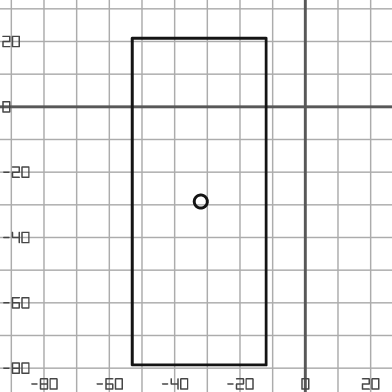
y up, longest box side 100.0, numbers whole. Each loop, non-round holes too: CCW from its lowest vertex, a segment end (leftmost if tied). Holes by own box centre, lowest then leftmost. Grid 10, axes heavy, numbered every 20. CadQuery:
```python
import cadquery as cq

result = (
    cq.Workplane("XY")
    .moveTo(-53.0, -79.0)
    .lineTo(-12.0, -79.0)
    .lineTo(-12.0, 21.0)
    .lineTo(-53.0, 21.0)
    .close()
    .moveTo(-32.0, -29.0)
    .circle(2.0)
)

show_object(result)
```